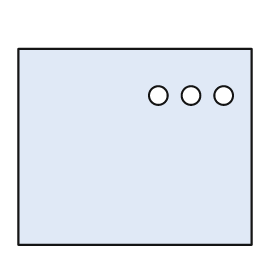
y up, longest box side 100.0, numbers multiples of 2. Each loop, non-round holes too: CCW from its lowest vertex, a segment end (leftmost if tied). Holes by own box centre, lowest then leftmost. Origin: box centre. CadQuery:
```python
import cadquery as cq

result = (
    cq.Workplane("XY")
    .moveTo(-50.0, -42.0)
    .lineTo(50.0, -42.0)
    .lineTo(50.0, 42.0)
    .lineTo(-50.0, 42.0)
    .close()
    .moveTo(10.0, 22.0)
    .circle(4.0)
    .moveTo(24.0, 22.0)
    .circle(4.0)
    .moveTo(38.0, 22.0)
    .circle(4.0)
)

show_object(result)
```